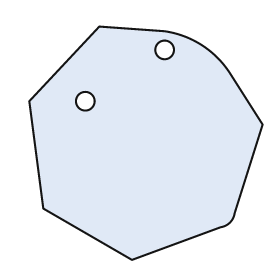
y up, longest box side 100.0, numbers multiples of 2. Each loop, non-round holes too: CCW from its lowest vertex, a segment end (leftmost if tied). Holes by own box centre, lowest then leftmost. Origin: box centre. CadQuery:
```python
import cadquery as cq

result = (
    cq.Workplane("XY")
    .moveTo(-6.0, -50.0)
    .lineTo(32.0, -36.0)
    .threePointArc((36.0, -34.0), (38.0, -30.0))
    .lineTo(50.0, 8.0)
    .lineTo(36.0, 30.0)
    .threePointArc((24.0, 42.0), (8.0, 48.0))
    .lineTo(-20.0, 50.0)
    .lineTo(-50.0, 18.0)
    .lineTo(-44.0, -28.0)
    .close()
    .moveTo(-26.0, 18.0)
    .circle(4.0)
    .moveTo(8.0, 40.0)
    .circle(4.0)
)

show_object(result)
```